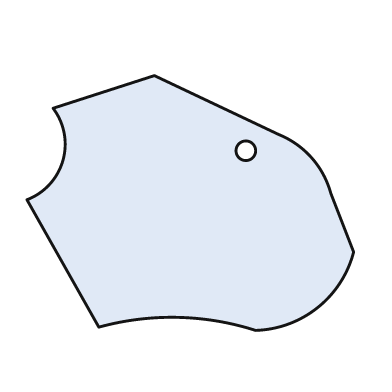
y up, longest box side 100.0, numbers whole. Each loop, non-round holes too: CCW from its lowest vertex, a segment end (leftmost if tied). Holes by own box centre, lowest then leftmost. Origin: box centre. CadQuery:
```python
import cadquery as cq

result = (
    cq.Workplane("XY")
    .moveTo(20.0, -39.0)
    .threePointArc((39.0, -32.0), (50.0, -15.0))
    .lineTo(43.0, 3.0)
    .threePointArc((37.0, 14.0), (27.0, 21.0))
    .lineTo(-11.0, 39.0)
    .lineTo(-42.0, 29.0)
    .threePointArc((-39.0, 13.0), (-50.0, 1.0))
    .lineTo(-28.0, -38.0)
    .threePointArc((-4.0, -35.0), (20.0, -39.0))
    .close()
    .moveTo(17.0, 16.0)
    .circle(3.0)
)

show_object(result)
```